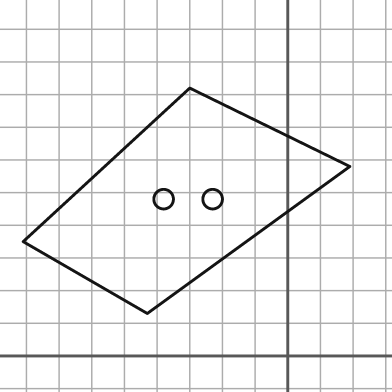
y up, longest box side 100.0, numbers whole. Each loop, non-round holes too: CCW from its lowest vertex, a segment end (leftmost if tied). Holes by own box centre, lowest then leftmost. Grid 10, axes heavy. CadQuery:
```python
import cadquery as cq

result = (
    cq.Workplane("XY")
    .moveTo(-43.0, 13.0)
    .lineTo(19.0, 58.0)
    .lineTo(-30.0, 82.0)
    .lineTo(-81.0, 35.0)
    .close()
    .moveTo(-38.0, 48.0)
    .circle(3.0)
    .moveTo(-23.0, 48.0)
    .circle(3.0)
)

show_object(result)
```